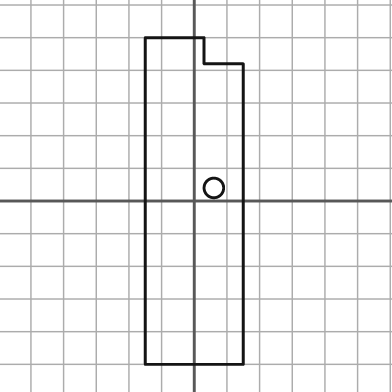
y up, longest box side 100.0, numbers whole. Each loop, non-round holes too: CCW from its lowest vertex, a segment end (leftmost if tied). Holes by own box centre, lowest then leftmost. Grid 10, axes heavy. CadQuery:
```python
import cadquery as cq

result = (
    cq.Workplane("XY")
    .moveTo(-15.0, -50.0)
    .lineTo(15.0, -50.0)
    .lineTo(15.0, 42.0)
    .lineTo(3.0, 42.0)
    .lineTo(3.0, 50.0)
    .lineTo(-15.0, 50.0)
    .close()
    .moveTo(6.0, 4.0)
    .circle(3.0)
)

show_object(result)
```